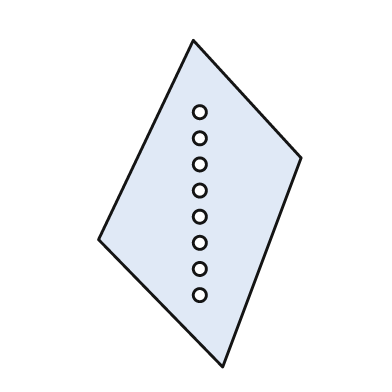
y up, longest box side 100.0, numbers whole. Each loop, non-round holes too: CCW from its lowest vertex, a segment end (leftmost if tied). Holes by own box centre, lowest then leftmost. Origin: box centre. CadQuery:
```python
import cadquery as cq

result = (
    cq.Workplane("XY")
    .moveTo(7.0, -50.0)
    .lineTo(31.0, 14.0)
    .lineTo(-2.0, 50.0)
    .lineTo(-31.0, -11.0)
    .close()
    .moveTo(0.0, -28.0)
    .circle(2.0)
    .moveTo(0.0, -20.0)
    .circle(2.0)
    .moveTo(0.0, -12.0)
    .circle(2.0)
    .moveTo(0.0, -4.0)
    .circle(2.0)
    .moveTo(0.0, 4.0)
    .circle(2.0)
    .moveTo(0.0, 12.0)
    .circle(2.0)
    .moveTo(0.0, 20.0)
    .circle(2.0)
    .moveTo(0.0, 28.0)
    .circle(2.0)
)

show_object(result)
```